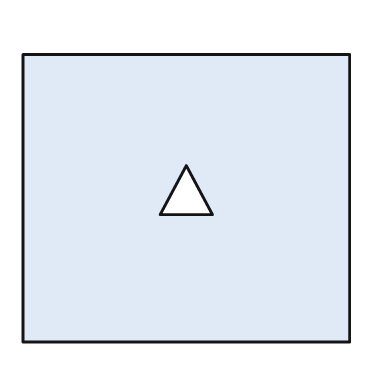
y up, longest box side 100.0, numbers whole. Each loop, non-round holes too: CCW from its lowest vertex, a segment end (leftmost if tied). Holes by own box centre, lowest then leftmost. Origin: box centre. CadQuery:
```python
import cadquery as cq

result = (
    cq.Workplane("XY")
    .moveTo(-50.0, -44.0)
    .lineTo(50.0, -44.0)
    .lineTo(50.0, 44.0)
    .lineTo(-50.0, 44.0)
    .close()
    .moveTo(-8.0, -5.0)
    .lineTo(8.0, -5.0)
    .lineTo(0.0, 10.0)
    .close()
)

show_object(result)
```